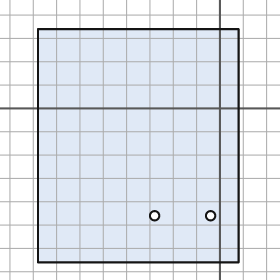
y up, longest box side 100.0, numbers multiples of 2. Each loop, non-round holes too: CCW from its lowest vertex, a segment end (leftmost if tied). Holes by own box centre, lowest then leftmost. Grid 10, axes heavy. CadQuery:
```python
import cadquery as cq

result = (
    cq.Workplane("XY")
    .moveTo(-78.0, -66.0)
    .lineTo(8.0, -66.0)
    .lineTo(8.0, 34.0)
    .lineTo(-78.0, 34.0)
    .close()
    .moveTo(-28.0, -46.0)
    .circle(2.0)
    .moveTo(-4.0, -46.0)
    .circle(2.0)
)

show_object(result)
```